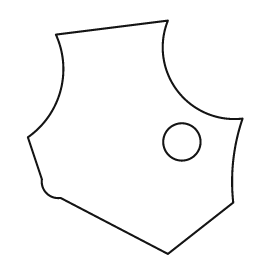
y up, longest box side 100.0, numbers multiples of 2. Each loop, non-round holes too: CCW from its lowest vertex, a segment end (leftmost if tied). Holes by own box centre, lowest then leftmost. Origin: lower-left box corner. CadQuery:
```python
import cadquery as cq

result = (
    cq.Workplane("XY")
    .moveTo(60.0, 0.0)
    .lineTo(88.0, 22.0)
    .threePointArc((88.0, 40.0), (92.0, 58.0))
    .threePointArc((64.0, 70.0), (60.0, 100.0))
    .lineTo(12.0, 94.0)
    .threePointArc((14.0, 70.0), (0.0, 50.0))
    .lineTo(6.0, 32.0)
    .threePointArc((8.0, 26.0), (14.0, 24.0))
    .close()
    .moveTo(66.0, 48.0)
    .circle(8.0)
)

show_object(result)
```